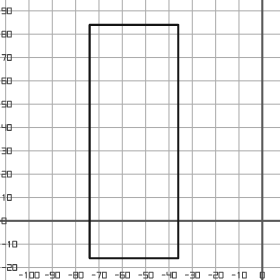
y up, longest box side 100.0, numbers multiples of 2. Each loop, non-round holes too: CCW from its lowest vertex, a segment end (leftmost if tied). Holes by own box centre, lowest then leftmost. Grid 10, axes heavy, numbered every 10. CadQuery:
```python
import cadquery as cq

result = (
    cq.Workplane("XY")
    .moveTo(-74.0, -16.0)
    .lineTo(-36.0, -16.0)
    .lineTo(-36.0, 84.0)
    .lineTo(-74.0, 84.0)
    .close()
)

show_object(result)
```